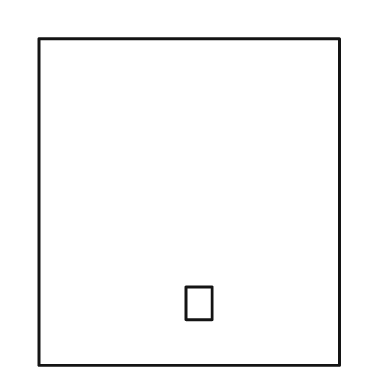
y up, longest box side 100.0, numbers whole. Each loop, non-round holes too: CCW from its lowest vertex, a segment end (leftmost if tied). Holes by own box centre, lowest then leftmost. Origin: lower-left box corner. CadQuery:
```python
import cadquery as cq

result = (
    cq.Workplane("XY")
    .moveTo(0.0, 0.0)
    .lineTo(92.0, 0.0)
    .lineTo(92.0, 100.0)
    .lineTo(0.0, 100.0)
    .close()
    .moveTo(45.0, 14.0)
    .lineTo(53.0, 14.0)
    .lineTo(53.0, 24.0)
    .lineTo(45.0, 24.0)
    .close()
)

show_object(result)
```